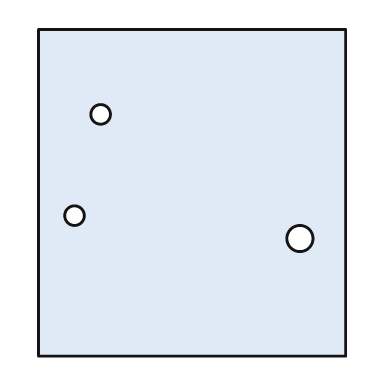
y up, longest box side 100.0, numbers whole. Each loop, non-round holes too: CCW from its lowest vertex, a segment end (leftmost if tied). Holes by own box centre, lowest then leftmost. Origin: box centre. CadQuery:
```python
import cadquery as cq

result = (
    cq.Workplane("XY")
    .moveTo(-47.0, -50.0)
    .lineTo(47.0, -50.0)
    .lineTo(47.0, 50.0)
    .lineTo(-47.0, 50.0)
    .close()
    .moveTo(33.0, -14.0)
    .circle(4.0)
    .moveTo(-36.0, -7.0)
    .circle(3.0)
    .moveTo(-28.0, 24.0)
    .circle(3.0)
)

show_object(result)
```